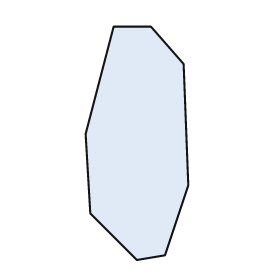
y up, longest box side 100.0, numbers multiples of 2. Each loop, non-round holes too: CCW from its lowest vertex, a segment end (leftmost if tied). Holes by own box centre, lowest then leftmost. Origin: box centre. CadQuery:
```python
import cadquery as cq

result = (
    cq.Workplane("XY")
    .moveTo(0.0, -50.0)
    .lineTo(12.0, -48.0)
    .lineTo(22.0, -18.0)
    .lineTo(20.0, 34.0)
    .lineTo(6.0, 50.0)
    .lineTo(-10.0, 50.0)
    .lineTo(-22.0, 4.0)
    .lineTo(-20.0, -30.0)
    .close()
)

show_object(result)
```